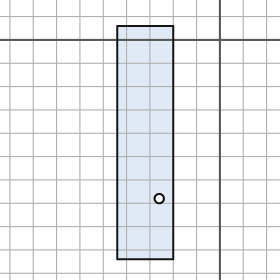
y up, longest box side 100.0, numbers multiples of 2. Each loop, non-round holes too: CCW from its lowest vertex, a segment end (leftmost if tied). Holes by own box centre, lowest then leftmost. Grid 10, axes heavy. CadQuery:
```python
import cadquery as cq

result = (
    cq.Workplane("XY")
    .moveTo(-44.0, -94.0)
    .lineTo(-20.0, -94.0)
    .lineTo(-20.0, 6.0)
    .lineTo(-44.0, 6.0)
    .close()
    .moveTo(-26.0, -68.0)
    .circle(2.0)
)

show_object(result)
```